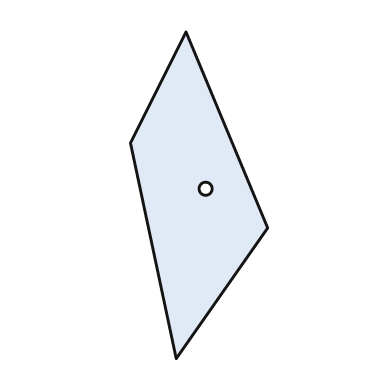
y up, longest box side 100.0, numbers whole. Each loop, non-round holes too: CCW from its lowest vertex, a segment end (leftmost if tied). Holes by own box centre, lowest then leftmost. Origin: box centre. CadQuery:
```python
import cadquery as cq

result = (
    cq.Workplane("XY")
    .moveTo(-7.0, -50.0)
    .lineTo(21.0, -10.0)
    .lineTo(-4.0, 50.0)
    .lineTo(-21.0, 16.0)
    .close()
    .moveTo(2.0, 2.0)
    .circle(2.0)
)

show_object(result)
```